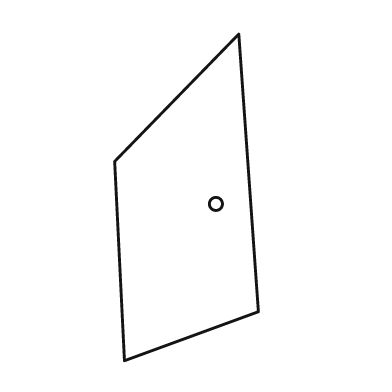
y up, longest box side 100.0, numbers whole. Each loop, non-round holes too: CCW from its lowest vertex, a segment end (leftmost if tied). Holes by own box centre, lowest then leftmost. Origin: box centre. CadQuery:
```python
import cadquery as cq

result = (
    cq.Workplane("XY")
    .moveTo(-19.0, -50.0)
    .lineTo(22.0, -35.0)
    .lineTo(16.0, 50.0)
    .lineTo(-22.0, 11.0)
    .close()
    .moveTo(9.0, -2.0)
    .circle(2.0)
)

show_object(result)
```